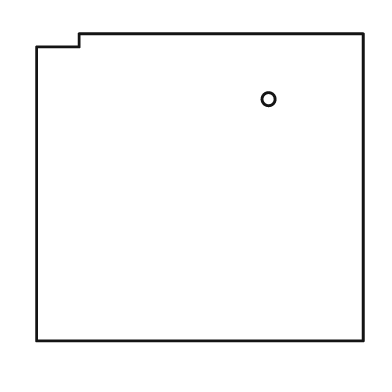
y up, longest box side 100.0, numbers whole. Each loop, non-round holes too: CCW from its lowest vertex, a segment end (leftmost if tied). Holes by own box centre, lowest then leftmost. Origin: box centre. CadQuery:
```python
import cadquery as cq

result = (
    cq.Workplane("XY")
    .moveTo(-50.0, -47.0)
    .lineTo(50.0, -47.0)
    .lineTo(50.0, 47.0)
    .lineTo(-37.0, 47.0)
    .lineTo(-37.0, 43.0)
    .lineTo(-50.0, 43.0)
    .close()
    .moveTo(21.0, 27.0)
    .circle(2.0)
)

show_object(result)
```